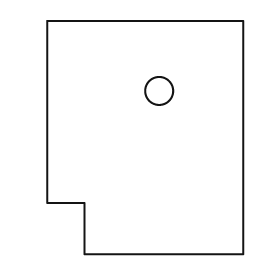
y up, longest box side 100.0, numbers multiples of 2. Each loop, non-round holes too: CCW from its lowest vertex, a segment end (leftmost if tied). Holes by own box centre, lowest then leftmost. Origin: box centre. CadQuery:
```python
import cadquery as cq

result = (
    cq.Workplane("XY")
    .moveTo(-26.0, -50.0)
    .lineTo(42.0, -50.0)
    .lineTo(42.0, 50.0)
    .lineTo(-42.0, 50.0)
    .lineTo(-42.0, -28.0)
    .lineTo(-26.0, -28.0)
    .close()
    .moveTo(6.0, 20.0)
    .circle(6.0)
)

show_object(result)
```